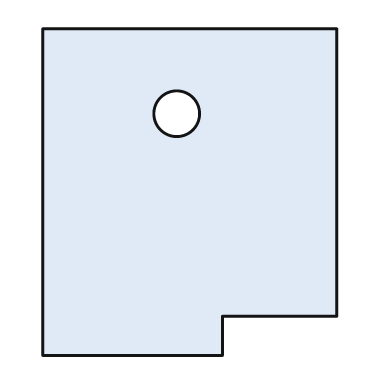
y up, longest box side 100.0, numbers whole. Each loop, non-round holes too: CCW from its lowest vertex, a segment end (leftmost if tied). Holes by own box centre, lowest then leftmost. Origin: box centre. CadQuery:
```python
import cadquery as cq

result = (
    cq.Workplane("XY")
    .moveTo(-45.0, -50.0)
    .lineTo(10.0, -50.0)
    .lineTo(10.0, -38.0)
    .lineTo(45.0, -38.0)
    .lineTo(45.0, 50.0)
    .lineTo(-45.0, 50.0)
    .close()
    .moveTo(-4.0, 24.0)
    .circle(7.0)
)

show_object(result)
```